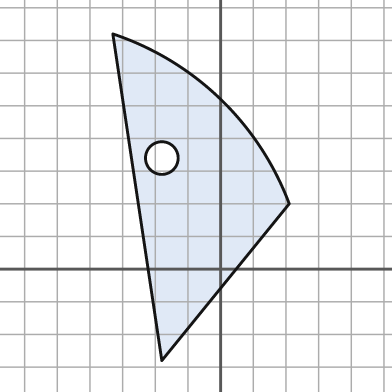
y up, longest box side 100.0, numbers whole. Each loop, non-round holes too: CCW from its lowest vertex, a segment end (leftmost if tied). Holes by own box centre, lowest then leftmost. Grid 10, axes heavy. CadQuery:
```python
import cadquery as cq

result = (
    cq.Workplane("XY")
    .moveTo(-18.0, -28.0)
    .lineTo(21.0, 20.0)
    .threePointArc((0.0, 52.0), (-33.0, 72.0))
    .close()
    .moveTo(-18.0, 34.0)
    .circle(5.0)
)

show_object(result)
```